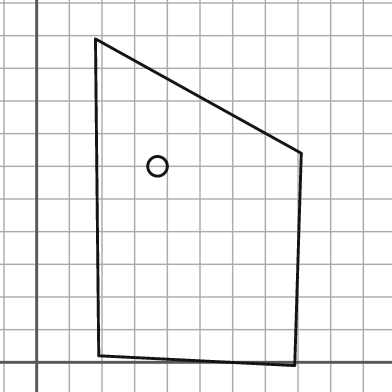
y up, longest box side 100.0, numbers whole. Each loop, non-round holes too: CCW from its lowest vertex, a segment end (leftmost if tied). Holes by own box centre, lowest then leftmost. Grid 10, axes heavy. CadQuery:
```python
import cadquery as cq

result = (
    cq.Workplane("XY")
    .moveTo(79.0, -1.0)
    .lineTo(81.0, 64.0)
    .lineTo(18.0, 99.0)
    .lineTo(19.0, 2.0)
    .close()
    .moveTo(37.0, 60.0)
    .circle(3.0)
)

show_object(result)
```